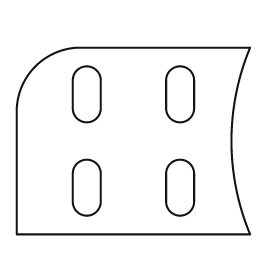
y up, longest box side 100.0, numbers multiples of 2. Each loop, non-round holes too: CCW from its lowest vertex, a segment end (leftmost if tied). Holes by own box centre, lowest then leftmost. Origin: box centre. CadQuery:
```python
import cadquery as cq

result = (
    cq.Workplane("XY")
    .moveTo(-50.0, -40.0)
    .lineTo(50.0, -40.0)
    .threePointArc((42.0, 0.0), (50.0, 40.0))
    .lineTo(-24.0, 40.0)
    .threePointArc((-42.0, 32.0), (-50.0, 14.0))
    .close()
    .moveTo(-26.0, -26.0)
    .threePointArc((-20.0, -32.0), (-14.0, -26.0))
    .lineTo(-14.0, -14.0)
    .threePointArc((-20.0, -8.0), (-26.0, -14.0))
    .close()
    .moveTo(14.0, -26.0)
    .threePointArc((20.0, -32.0), (26.0, -26.0))
    .lineTo(26.0, -14.0)
    .threePointArc((20.0, -8.0), (14.0, -14.0))
    .close()
    .moveTo(-26.0, 14.0)
    .threePointArc((-20.0, 8.0), (-14.0, 14.0))
    .lineTo(-14.0, 26.0)
    .threePointArc((-20.0, 32.0), (-26.0, 26.0))
    .close()
    .moveTo(14.0, 14.0)
    .threePointArc((20.0, 8.0), (26.0, 14.0))
    .lineTo(26.0, 26.0)
    .threePointArc((20.0, 32.0), (14.0, 26.0))
    .close()
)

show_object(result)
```